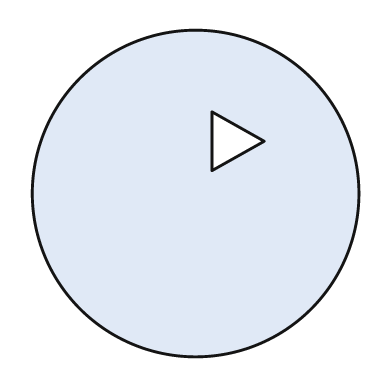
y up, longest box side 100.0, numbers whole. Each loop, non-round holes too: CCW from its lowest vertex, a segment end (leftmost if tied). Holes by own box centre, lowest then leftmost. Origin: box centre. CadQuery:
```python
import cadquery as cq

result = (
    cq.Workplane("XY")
    .moveTo(0.0, 0.0)
    .circle(50.0)
    .moveTo(5.0, 7.0)
    .lineTo(21.0, 16.0)
    .lineTo(5.0, 25.0)
    .close()
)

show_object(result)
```